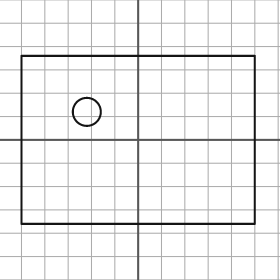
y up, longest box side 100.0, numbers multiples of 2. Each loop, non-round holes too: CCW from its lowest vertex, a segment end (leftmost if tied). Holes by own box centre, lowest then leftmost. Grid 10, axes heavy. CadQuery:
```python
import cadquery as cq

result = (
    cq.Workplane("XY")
    .moveTo(-50.0, -36.0)
    .lineTo(50.0, -36.0)
    .lineTo(50.0, 36.0)
    .lineTo(-50.0, 36.0)
    .close()
    .moveTo(-22.0, 12.0)
    .circle(6.0)
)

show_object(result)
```